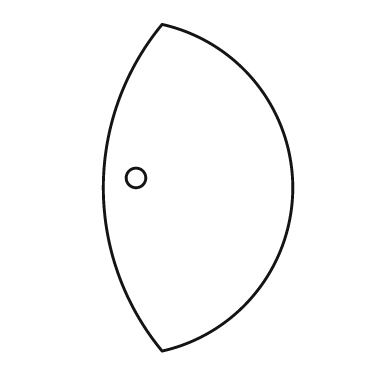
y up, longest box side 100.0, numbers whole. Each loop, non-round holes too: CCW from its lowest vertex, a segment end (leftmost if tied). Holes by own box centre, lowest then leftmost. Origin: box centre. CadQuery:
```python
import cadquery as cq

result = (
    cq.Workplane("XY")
    .moveTo(-11.0, -50.0)
    .threePointArc((29.0, 0.0), (-11.0, 50.0))
    .threePointArc((-29.0, 0.0), (-11.0, -50.0))
    .close()
    .moveTo(-19.0, 3.0)
    .circle(3.0)
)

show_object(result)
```